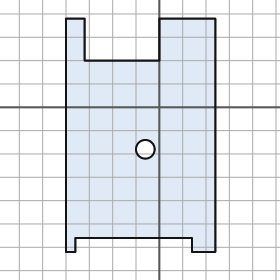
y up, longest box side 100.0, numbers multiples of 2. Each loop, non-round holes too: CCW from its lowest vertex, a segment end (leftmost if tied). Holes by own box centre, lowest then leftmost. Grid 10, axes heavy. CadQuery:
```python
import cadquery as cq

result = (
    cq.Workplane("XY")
    .moveTo(-40.0, -62.0)
    .lineTo(-36.0, -62.0)
    .lineTo(-36.0, -56.0)
    .lineTo(14.0, -56.0)
    .lineTo(14.0, -62.0)
    .lineTo(24.0, -62.0)
    .lineTo(24.0, 38.0)
    .lineTo(0.0, 38.0)
    .lineTo(0.0, 20.0)
    .lineTo(-32.0, 20.0)
    .lineTo(-32.0, 38.0)
    .lineTo(-40.0, 38.0)
    .close()
    .moveTo(-6.0, -18.0)
    .circle(4.0)
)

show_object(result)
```